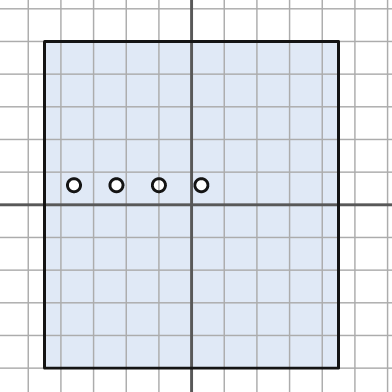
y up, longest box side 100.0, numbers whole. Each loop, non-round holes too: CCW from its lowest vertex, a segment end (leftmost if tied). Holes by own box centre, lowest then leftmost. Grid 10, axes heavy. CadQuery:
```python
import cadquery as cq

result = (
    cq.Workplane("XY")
    .moveTo(-45.0, -50.0)
    .lineTo(45.0, -50.0)
    .lineTo(45.0, 50.0)
    .lineTo(-45.0, 50.0)
    .close()
    .moveTo(-36.0, 6.0)
    .circle(2.0)
    .moveTo(-23.0, 6.0)
    .circle(2.0)
    .moveTo(-10.0, 6.0)
    .circle(2.0)
    .moveTo(3.0, 6.0)
    .circle(2.0)
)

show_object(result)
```